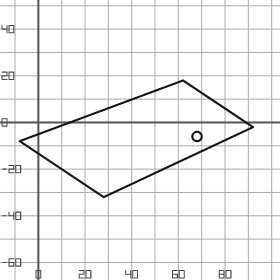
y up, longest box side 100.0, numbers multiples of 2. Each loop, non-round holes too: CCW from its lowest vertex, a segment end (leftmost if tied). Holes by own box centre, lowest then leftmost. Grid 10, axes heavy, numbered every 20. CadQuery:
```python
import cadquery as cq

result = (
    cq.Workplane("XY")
    .moveTo(28.0, -32.0)
    .lineTo(92.0, -2.0)
    .lineTo(62.0, 18.0)
    .lineTo(-8.0, -8.0)
    .close()
    .moveTo(68.0, -6.0)
    .circle(2.0)
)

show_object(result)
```